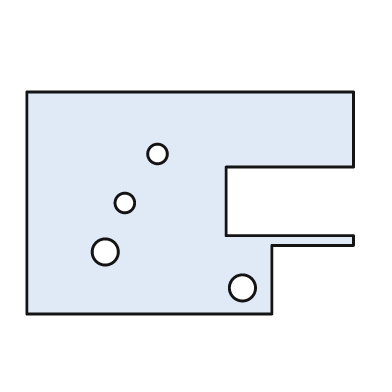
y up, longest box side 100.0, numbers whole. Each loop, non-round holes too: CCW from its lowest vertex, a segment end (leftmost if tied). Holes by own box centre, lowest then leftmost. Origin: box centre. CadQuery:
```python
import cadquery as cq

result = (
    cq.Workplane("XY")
    .moveTo(-50.0, -34.0)
    .lineTo(25.0, -34.0)
    .lineTo(25.0, -13.0)
    .lineTo(50.0, -13.0)
    .lineTo(50.0, -10.0)
    .lineTo(11.0, -10.0)
    .lineTo(11.0, 11.0)
    .lineTo(50.0, 11.0)
    .lineTo(50.0, 34.0)
    .lineTo(-50.0, 34.0)
    .close()
    .moveTo(16.0, -26.0)
    .circle(4.0)
    .moveTo(-26.0, -15.0)
    .circle(4.0)
    .moveTo(-20.0, 0.0)
    .circle(3.0)
    .moveTo(-10.0, 15.0)
    .circle(3.0)
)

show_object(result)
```